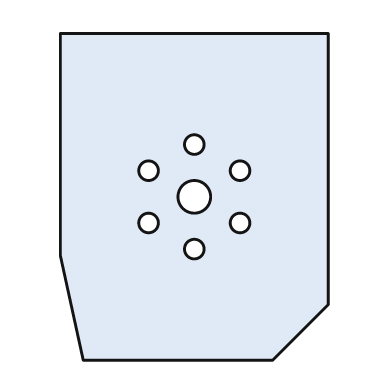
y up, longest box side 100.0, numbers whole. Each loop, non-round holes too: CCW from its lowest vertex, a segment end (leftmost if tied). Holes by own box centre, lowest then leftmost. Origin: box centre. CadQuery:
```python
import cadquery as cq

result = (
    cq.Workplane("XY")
    .moveTo(-34.0, -50.0)
    .lineTo(24.0, -50.0)
    .lineTo(41.0, -33.0)
    .lineTo(41.0, 50.0)
    .lineTo(-41.0, 50.0)
    .lineTo(-41.0, -18.0)
    .close()
    .moveTo(0.0, -16.0)
    .circle(3.0)
    .moveTo(-14.0, -8.0)
    .circle(3.0)
    .moveTo(14.0, -8.0)
    .circle(3.0)
    .moveTo(0.0, 0.0)
    .circle(5.0)
    .moveTo(-14.0, 8.0)
    .circle(3.0)
    .moveTo(14.0, 8.0)
    .circle(3.0)
    .moveTo(0.0, 16.0)
    .circle(3.0)
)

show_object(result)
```